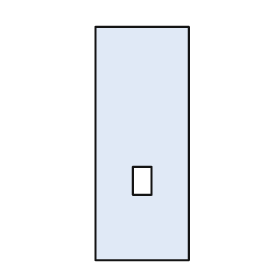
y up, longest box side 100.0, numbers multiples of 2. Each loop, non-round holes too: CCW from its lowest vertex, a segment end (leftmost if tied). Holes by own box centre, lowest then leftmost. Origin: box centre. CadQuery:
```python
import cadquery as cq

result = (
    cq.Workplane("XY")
    .moveTo(-20.0, -50.0)
    .lineTo(20.0, -50.0)
    .lineTo(20.0, 50.0)
    .lineTo(-20.0, 50.0)
    .close()
    .moveTo(-4.0, -22.0)
    .lineTo(4.0, -22.0)
    .lineTo(4.0, -10.0)
    .lineTo(-4.0, -10.0)
    .close()
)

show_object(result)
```